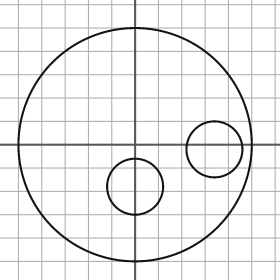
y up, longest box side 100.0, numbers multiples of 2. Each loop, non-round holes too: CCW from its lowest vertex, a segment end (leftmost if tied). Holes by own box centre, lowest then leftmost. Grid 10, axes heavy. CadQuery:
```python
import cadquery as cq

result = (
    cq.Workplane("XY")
    .moveTo(0.0, 0.0)
    .circle(50.0)
    .moveTo(0.0, -18.0)
    .circle(12.0)
    .moveTo(34.0, -2.0)
    .circle(12.0)
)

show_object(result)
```